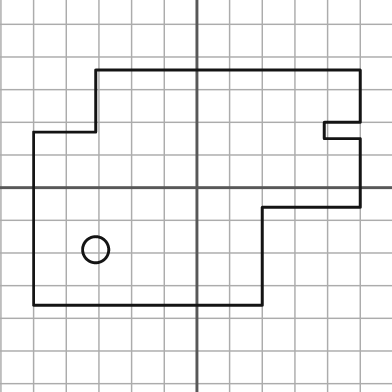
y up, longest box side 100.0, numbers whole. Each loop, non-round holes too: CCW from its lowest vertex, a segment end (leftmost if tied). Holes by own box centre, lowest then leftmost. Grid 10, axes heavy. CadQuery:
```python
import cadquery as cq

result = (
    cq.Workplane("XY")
    .moveTo(-50.0, -36.0)
    .lineTo(20.0, -36.0)
    .lineTo(20.0, -6.0)
    .lineTo(50.0, -6.0)
    .lineTo(50.0, 15.0)
    .lineTo(39.0, 15.0)
    .lineTo(39.0, 20.0)
    .lineTo(50.0, 20.0)
    .lineTo(50.0, 36.0)
    .lineTo(-31.0, 36.0)
    .lineTo(-31.0, 17.0)
    .lineTo(-50.0, 17.0)
    .close()
    .moveTo(-31.0, -19.0)
    .circle(4.0)
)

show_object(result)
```